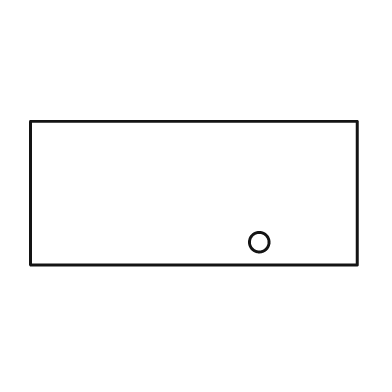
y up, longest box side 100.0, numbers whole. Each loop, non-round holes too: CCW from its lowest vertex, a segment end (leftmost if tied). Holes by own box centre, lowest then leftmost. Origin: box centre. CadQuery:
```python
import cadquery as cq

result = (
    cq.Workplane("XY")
    .moveTo(-50.0, -22.0)
    .lineTo(50.0, -22.0)
    .lineTo(50.0, 22.0)
    .lineTo(-50.0, 22.0)
    .close()
    .moveTo(20.0, -15.0)
    .circle(3.0)
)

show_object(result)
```